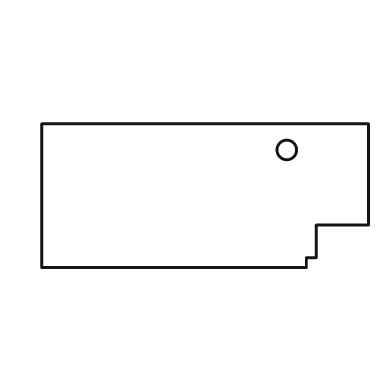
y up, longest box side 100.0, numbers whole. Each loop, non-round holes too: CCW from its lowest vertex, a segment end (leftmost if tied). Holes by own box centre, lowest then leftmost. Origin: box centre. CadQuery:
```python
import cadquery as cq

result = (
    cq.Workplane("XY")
    .moveTo(-50.0, -22.0)
    .lineTo(31.0, -22.0)
    .lineTo(31.0, -19.0)
    .lineTo(34.0, -19.0)
    .lineTo(34.0, -9.0)
    .lineTo(50.0, -9.0)
    .lineTo(50.0, 22.0)
    .lineTo(-50.0, 22.0)
    .close()
    .moveTo(25.0, 14.0)
    .circle(3.0)
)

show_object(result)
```